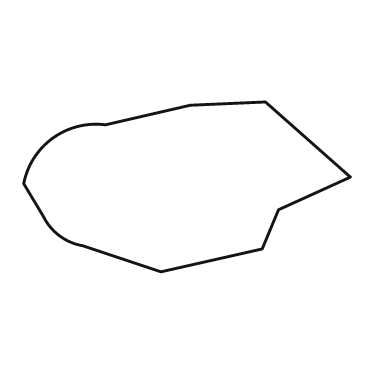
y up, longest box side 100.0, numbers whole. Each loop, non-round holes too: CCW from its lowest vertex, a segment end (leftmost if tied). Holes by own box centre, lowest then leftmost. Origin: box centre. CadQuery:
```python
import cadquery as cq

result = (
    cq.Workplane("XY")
    .moveTo(-8.0, -26.0)
    .lineTo(23.0, -19.0)
    .lineTo(28.0, -7.0)
    .lineTo(50.0, 3.0)
    .lineTo(24.0, 26.0)
    .lineTo(1.0, 25.0)
    .lineTo(-25.0, 19.0)
    .threePointArc((-41.0, 15.0), (-50.0, 1.0))
    .lineTo(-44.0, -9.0)
    .threePointArc((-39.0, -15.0), (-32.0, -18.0))
    .close()
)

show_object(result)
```